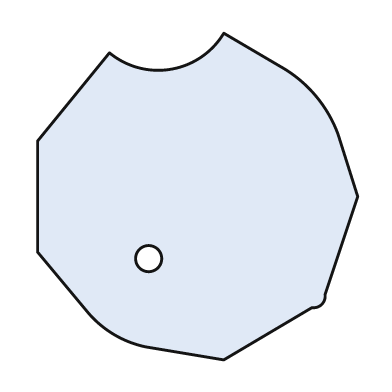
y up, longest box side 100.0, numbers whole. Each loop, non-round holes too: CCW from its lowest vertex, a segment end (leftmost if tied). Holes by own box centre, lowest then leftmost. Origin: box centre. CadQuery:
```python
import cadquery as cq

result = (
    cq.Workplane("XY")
    .moveTo(8.0, -50.0)
    .lineTo(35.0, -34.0)
    .threePointArc((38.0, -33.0), (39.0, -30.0))
    .lineTo(49.0, 0.0)
    .lineTo(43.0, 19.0)
    .threePointArc((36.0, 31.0), (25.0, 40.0))
    .lineTo(8.0, 50.0)
    .threePointArc((-8.0, 39.0), (-27.0, 44.0))
    .lineTo(-49.0, 17.0)
    .lineTo(-49.0, -17.0)
    .lineTo(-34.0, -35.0)
    .threePointArc((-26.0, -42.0), (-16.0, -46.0))
    .close()
    .moveTo(-15.0, -19.0)
    .circle(4.0)
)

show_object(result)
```